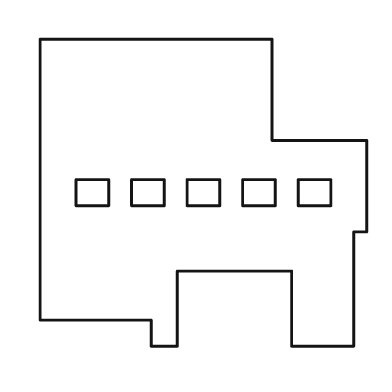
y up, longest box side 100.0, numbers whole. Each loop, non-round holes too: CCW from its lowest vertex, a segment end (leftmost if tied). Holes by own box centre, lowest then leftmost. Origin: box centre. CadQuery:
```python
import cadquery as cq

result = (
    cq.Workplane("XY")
    .moveTo(-16.0, -47.0)
    .lineTo(-8.0, -47.0)
    .lineTo(-8.0, -24.0)
    .lineTo(27.0, -24.0)
    .lineTo(27.0, -47.0)
    .lineTo(46.0, -47.0)
    .lineTo(46.0, -12.0)
    .lineTo(50.0, -12.0)
    .lineTo(50.0, 16.0)
    .lineTo(21.0, 16.0)
    .lineTo(21.0, 47.0)
    .lineTo(-50.0, 47.0)
    .lineTo(-50.0, -39.0)
    .lineTo(-16.0, -39.0)
    .close()
    .moveTo(-39.0, -4.0)
    .lineTo(-29.0, -4.0)
    .lineTo(-29.0, 4.0)
    .lineTo(-39.0, 4.0)
    .close()
    .moveTo(-22.0, -4.0)
    .lineTo(-12.0, -4.0)
    .lineTo(-12.0, 4.0)
    .lineTo(-22.0, 4.0)
    .close()
    .moveTo(-5.0, -4.0)
    .lineTo(5.0, -4.0)
    .lineTo(5.0, 4.0)
    .lineTo(-5.0, 4.0)
    .close()
    .moveTo(12.0, -4.0)
    .lineTo(22.0, -4.0)
    .lineTo(22.0, 4.0)
    .lineTo(12.0, 4.0)
    .close()
    .moveTo(29.0, -4.0)
    .lineTo(39.0, -4.0)
    .lineTo(39.0, 4.0)
    .lineTo(29.0, 4.0)
    .close()
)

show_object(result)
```